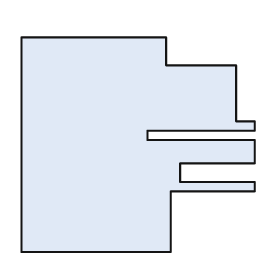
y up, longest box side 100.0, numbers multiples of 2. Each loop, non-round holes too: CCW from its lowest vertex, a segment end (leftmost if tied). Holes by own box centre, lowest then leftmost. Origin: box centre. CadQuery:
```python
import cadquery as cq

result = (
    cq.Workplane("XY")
    .moveTo(-50.0, -46.0)
    .lineTo(14.0, -46.0)
    .lineTo(14.0, -20.0)
    .lineTo(50.0, -20.0)
    .lineTo(50.0, -16.0)
    .lineTo(18.0, -16.0)
    .lineTo(18.0, -8.0)
    .lineTo(50.0, -8.0)
    .lineTo(50.0, 2.0)
    .lineTo(4.0, 2.0)
    .lineTo(4.0, 6.0)
    .lineTo(50.0, 6.0)
    .lineTo(50.0, 10.0)
    .lineTo(42.0, 10.0)
    .lineTo(42.0, 34.0)
    .lineTo(12.0, 34.0)
    .lineTo(12.0, 46.0)
    .lineTo(-50.0, 46.0)
    .close()
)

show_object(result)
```